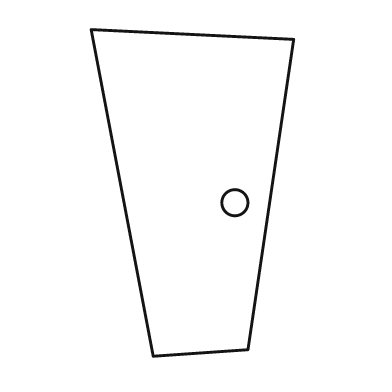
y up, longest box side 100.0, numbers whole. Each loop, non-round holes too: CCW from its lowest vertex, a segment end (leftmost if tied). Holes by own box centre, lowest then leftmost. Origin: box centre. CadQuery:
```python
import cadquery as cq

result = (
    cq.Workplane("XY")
    .moveTo(-12.0, -50.0)
    .lineTo(17.0, -48.0)
    .lineTo(31.0, 47.0)
    .lineTo(-31.0, 50.0)
    .close()
    .moveTo(13.0, -3.0)
    .circle(4.0)
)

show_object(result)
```